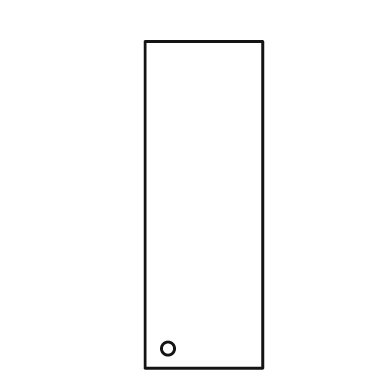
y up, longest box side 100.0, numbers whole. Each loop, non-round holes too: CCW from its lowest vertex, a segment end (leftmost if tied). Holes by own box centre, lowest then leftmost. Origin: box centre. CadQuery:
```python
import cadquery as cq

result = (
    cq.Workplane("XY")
    .moveTo(-18.0, -50.0)
    .lineTo(18.0, -50.0)
    .lineTo(18.0, 50.0)
    .lineTo(-18.0, 50.0)
    .close()
    .moveTo(-11.0, -44.0)
    .circle(2.0)
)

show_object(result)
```